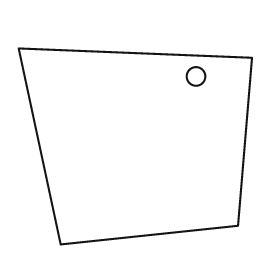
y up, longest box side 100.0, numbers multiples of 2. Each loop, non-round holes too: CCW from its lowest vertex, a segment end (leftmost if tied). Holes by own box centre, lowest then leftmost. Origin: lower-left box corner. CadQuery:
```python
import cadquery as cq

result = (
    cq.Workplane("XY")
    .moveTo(18.0, 0.0)
    .lineTo(94.0, 8.0)
    .lineTo(100.0, 80.0)
    .lineTo(0.0, 84.0)
    .close()
    .moveTo(76.0, 72.0)
    .circle(4.0)
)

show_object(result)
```